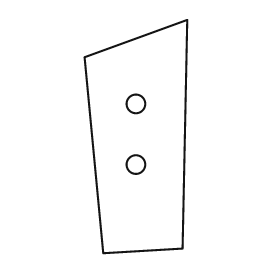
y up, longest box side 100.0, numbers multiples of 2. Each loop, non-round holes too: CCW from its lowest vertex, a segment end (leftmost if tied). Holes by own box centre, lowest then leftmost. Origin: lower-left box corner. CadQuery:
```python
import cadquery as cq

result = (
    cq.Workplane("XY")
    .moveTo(8.0, 0.0)
    .lineTo(42.0, 2.0)
    .lineTo(44.0, 100.0)
    .lineTo(0.0, 84.0)
    .close()
    .moveTo(22.0, 38.0)
    .circle(4.0)
    .moveTo(22.0, 64.0)
    .circle(4.0)
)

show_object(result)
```